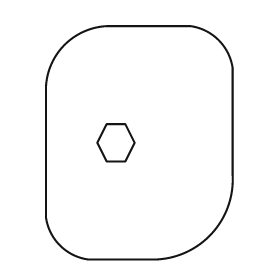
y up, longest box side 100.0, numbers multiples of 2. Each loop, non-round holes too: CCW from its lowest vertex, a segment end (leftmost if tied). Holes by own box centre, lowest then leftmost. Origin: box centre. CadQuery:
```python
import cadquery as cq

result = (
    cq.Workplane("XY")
    .moveTo(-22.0, -50.0)
    .lineTo(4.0, -50.0)
    .threePointArc((30.0, -40.0), (40.0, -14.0))
    .lineTo(40.0, 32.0)
    .threePointArc((34.0, 44.0), (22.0, 50.0))
    .lineTo(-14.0, 50.0)
    .threePointArc((-32.0, 42.0), (-40.0, 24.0))
    .lineTo(-40.0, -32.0)
    .threePointArc((-34.0, -44.0), (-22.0, -50.0))
    .close()
    .moveTo(-14.0, -8.0)
    .lineTo(-6.0, -8.0)
    .lineTo(-2.0, 0.0)
    .lineTo(-6.0, 8.0)
    .lineTo(-14.0, 8.0)
    .lineTo(-18.0, 0.0)
    .close()
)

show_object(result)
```